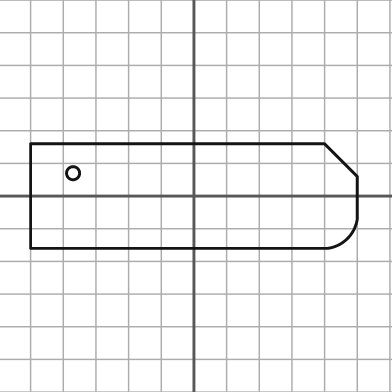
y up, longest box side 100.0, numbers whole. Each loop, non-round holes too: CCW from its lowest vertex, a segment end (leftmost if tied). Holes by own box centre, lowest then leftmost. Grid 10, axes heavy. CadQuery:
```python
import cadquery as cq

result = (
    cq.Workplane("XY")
    .moveTo(-50.0, -16.0)
    .lineTo(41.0, -16.0)
    .threePointArc((47.0, -13.0), (50.0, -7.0))
    .lineTo(50.0, 6.0)
    .lineTo(40.0, 16.0)
    .lineTo(-50.0, 16.0)
    .close()
    .moveTo(-37.0, 7.0)
    .circle(2.0)
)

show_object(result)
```